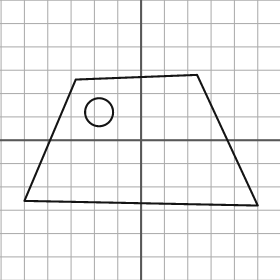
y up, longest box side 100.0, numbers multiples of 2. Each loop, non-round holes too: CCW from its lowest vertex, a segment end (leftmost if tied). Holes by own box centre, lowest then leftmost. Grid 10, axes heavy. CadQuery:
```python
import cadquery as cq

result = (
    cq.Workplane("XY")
    .moveTo(50.0, -28.0)
    .lineTo(24.0, 28.0)
    .lineTo(-28.0, 26.0)
    .lineTo(-50.0, -26.0)
    .close()
    .moveTo(-18.0, 12.0)
    .circle(6.0)
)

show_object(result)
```